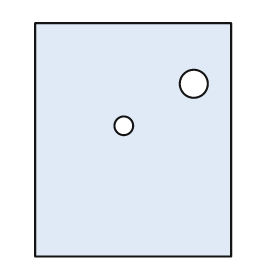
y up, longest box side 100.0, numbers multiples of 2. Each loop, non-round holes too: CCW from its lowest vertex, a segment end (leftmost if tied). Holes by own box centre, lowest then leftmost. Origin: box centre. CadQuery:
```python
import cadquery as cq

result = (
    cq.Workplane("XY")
    .moveTo(-42.0, -50.0)
    .lineTo(42.0, -50.0)
    .lineTo(42.0, 50.0)
    .lineTo(-42.0, 50.0)
    .close()
    .moveTo(-4.0, 6.0)
    .circle(4.0)
    .moveTo(26.0, 24.0)
    .circle(6.0)
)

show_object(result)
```